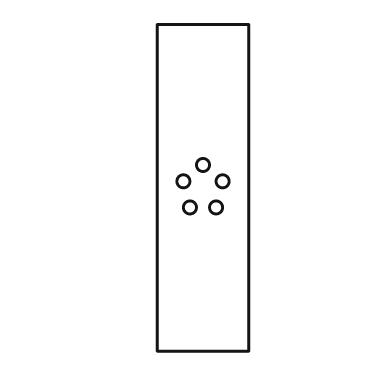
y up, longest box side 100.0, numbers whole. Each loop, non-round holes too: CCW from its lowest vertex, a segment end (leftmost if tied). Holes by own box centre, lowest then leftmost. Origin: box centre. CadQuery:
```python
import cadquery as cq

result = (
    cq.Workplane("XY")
    .moveTo(-14.0, -50.0)
    .lineTo(14.0, -50.0)
    .lineTo(14.0, 50.0)
    .lineTo(-14.0, 50.0)
    .close()
    .moveTo(-4.0, -6.0)
    .circle(2.0)
    .moveTo(4.0, -6.0)
    .circle(2.0)
    .moveTo(-6.0, 2.0)
    .circle(2.0)
    .moveTo(6.0, 2.0)
    .circle(2.0)
    .moveTo(0.0, 7.0)
    .circle(2.0)
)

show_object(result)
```